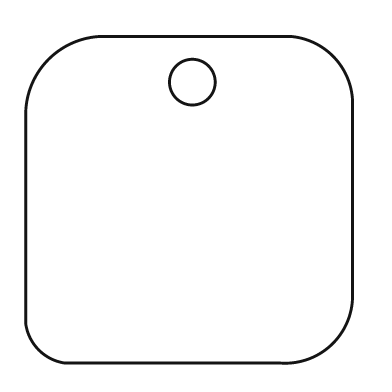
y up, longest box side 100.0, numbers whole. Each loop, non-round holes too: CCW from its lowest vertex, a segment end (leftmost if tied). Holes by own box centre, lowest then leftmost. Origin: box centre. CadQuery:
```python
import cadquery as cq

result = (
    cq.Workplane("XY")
    .moveTo(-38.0, -50.0)
    .lineTo(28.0, -50.0)
    .threePointArc((44.0, -44.0), (50.0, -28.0))
    .lineTo(50.0, 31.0)
    .threePointArc((44.0, 44.0), (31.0, 50.0))
    .lineTo(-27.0, 50.0)
    .threePointArc((-43.0, 43.0), (-50.0, 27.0))
    .lineTo(-50.0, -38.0)
    .threePointArc((-46.0, -46.0), (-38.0, -50.0))
    .close()
    .moveTo(1.0, 36.0)
    .circle(7.0)
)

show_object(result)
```